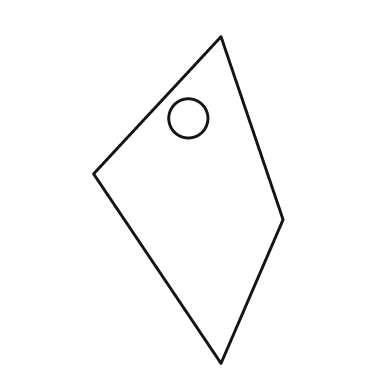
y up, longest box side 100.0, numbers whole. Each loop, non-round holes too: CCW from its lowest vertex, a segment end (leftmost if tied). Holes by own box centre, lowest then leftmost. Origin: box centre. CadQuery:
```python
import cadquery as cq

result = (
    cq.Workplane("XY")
    .moveTo(10.0, -50.0)
    .lineTo(29.0, -6.0)
    .lineTo(10.0, 50.0)
    .lineTo(-29.0, 8.0)
    .close()
    .moveTo(0.0, 25.0)
    .circle(6.0)
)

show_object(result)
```